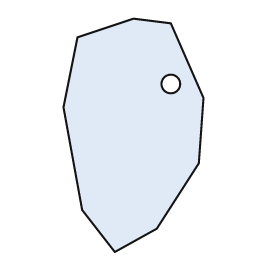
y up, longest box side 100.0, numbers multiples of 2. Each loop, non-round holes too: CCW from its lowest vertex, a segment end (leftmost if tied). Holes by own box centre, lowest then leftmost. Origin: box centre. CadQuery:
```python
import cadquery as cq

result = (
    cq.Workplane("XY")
    .moveTo(-8.0, -50.0)
    .lineTo(10.0, -40.0)
    .lineTo(28.0, -12.0)
    .lineTo(30.0, 16.0)
    .lineTo(16.0, 48.0)
    .lineTo(0.0, 50.0)
    .lineTo(-24.0, 42.0)
    .lineTo(-30.0, 12.0)
    .lineTo(-22.0, -32.0)
    .close()
    .moveTo(16.0, 22.0)
    .circle(4.0)
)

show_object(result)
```